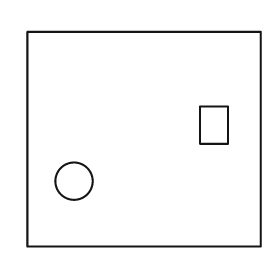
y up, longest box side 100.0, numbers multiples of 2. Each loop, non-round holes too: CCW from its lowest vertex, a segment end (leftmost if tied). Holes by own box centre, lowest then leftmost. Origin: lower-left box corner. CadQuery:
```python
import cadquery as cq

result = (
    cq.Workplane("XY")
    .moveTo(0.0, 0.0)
    .lineTo(100.0, 0.0)
    .lineTo(100.0, 92.0)
    .lineTo(0.0, 92.0)
    .close()
    .moveTo(20.0, 28.0)
    .circle(8.0)
    .moveTo(74.0, 44.0)
    .lineTo(86.0, 44.0)
    .lineTo(86.0, 60.0)
    .lineTo(74.0, 60.0)
    .close()
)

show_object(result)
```